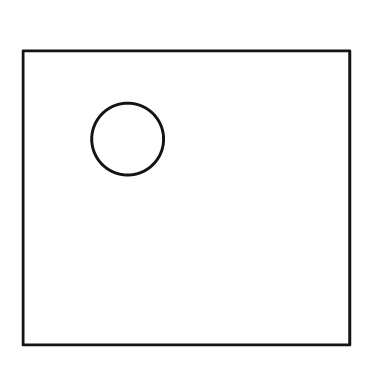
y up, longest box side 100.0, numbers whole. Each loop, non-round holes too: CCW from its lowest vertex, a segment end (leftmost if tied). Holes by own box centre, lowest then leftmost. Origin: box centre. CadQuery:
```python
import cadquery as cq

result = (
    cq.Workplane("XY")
    .moveTo(-50.0, -45.0)
    .lineTo(50.0, -45.0)
    .lineTo(50.0, 45.0)
    .lineTo(-50.0, 45.0)
    .close()
    .moveTo(-18.0, 18.0)
    .circle(11.0)
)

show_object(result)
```